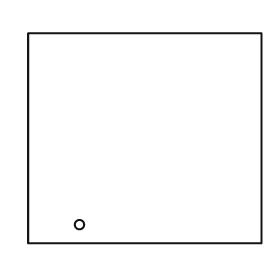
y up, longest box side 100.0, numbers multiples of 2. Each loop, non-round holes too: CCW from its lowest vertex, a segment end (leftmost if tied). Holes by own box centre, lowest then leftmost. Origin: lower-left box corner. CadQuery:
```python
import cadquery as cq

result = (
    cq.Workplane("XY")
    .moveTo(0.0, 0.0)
    .lineTo(100.0, 0.0)
    .lineTo(100.0, 90.0)
    .lineTo(0.0, 90.0)
    .close()
    .moveTo(22.0, 8.0)
    .circle(2.0)
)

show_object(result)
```